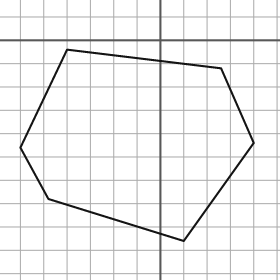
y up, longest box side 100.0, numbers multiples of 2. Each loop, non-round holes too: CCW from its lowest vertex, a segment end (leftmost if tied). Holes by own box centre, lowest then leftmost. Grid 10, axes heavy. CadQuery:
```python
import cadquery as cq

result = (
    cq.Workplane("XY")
    .moveTo(10.0, -86.0)
    .lineTo(40.0, -44.0)
    .lineTo(26.0, -12.0)
    .lineTo(-40.0, -4.0)
    .lineTo(-60.0, -46.0)
    .lineTo(-48.0, -68.0)
    .close()
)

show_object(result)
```